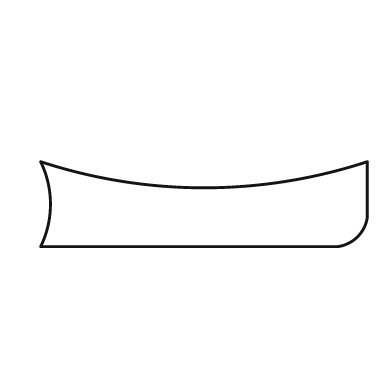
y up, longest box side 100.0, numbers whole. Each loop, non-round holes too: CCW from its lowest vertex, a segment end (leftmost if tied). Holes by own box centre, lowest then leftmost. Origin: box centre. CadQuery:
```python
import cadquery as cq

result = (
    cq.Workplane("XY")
    .moveTo(-50.0, -13.0)
    .lineTo(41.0, -13.0)
    .threePointArc((47.0, -10.0), (50.0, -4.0))
    .lineTo(50.0, 13.0)
    .threePointArc((0.0, 5.0), (-50.0, 13.0))
    .threePointArc((-47.0, 0.0), (-50.0, -13.0))
    .close()
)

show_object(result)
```